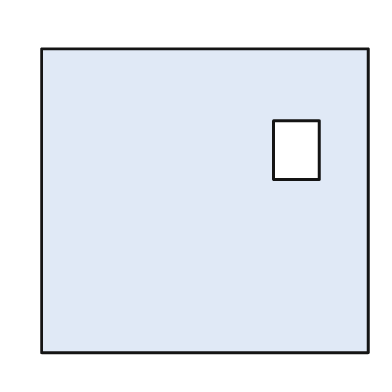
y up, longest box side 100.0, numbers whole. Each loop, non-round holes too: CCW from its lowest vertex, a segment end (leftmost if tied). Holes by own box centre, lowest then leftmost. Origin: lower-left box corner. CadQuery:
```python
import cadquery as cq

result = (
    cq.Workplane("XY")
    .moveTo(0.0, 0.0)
    .lineTo(100.0, 0.0)
    .lineTo(100.0, 93.0)
    .lineTo(0.0, 93.0)
    .close()
    .moveTo(71.0, 53.0)
    .lineTo(85.0, 53.0)
    .lineTo(85.0, 71.0)
    .lineTo(71.0, 71.0)
    .close()
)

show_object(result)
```